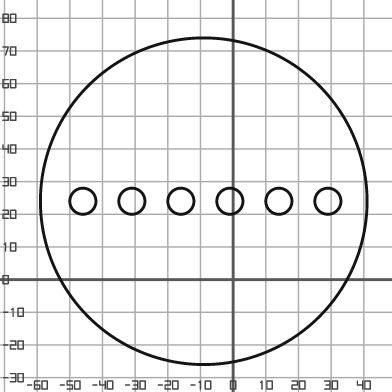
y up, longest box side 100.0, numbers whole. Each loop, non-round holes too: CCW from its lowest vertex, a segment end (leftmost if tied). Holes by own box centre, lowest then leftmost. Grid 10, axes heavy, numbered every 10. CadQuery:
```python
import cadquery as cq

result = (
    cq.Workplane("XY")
    .moveTo(-9.0, 24.0)
    .circle(50.0)
    .moveTo(-46.0, 24.0)
    .circle(4.0)
    .moveTo(-31.0, 24.0)
    .circle(4.0)
    .moveTo(-16.0, 24.0)
    .circle(4.0)
    .moveTo(-1.0, 24.0)
    .circle(4.0)
    .moveTo(14.0, 24.0)
    .circle(4.0)
    .moveTo(29.0, 24.0)
    .circle(4.0)
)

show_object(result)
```